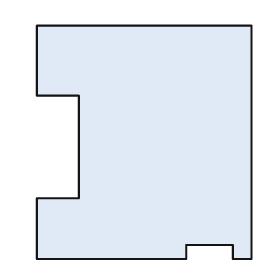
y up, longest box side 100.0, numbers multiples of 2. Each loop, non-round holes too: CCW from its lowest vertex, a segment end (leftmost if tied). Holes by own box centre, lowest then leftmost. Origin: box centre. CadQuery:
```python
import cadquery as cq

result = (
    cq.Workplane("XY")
    .moveTo(-46.0, -50.0)
    .lineTo(18.0, -50.0)
    .lineTo(18.0, -44.0)
    .lineTo(38.0, -44.0)
    .lineTo(38.0, -50.0)
    .lineTo(46.0, -50.0)
    .lineTo(46.0, 50.0)
    .lineTo(-46.0, 50.0)
    .lineTo(-46.0, 20.0)
    .lineTo(-28.0, 20.0)
    .lineTo(-28.0, -24.0)
    .lineTo(-46.0, -24.0)
    .close()
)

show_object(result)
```